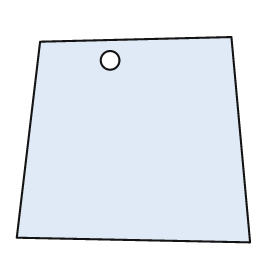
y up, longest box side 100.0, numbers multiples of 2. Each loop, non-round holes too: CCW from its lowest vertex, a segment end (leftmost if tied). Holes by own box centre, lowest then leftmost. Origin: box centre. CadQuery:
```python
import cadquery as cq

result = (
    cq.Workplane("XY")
    .moveTo(50.0, -44.0)
    .lineTo(42.0, 44.0)
    .lineTo(-40.0, 42.0)
    .lineTo(-50.0, -42.0)
    .close()
    .moveTo(-10.0, 34.0)
    .circle(4.0)
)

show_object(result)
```